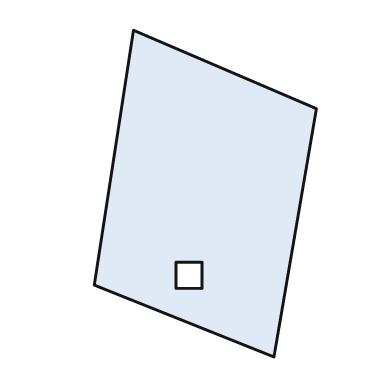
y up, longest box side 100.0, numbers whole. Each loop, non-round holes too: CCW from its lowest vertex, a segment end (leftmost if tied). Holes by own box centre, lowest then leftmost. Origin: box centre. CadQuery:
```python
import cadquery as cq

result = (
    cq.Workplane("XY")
    .moveTo(21.0, -50.0)
    .lineTo(34.0, 26.0)
    .lineTo(-22.0, 50.0)
    .lineTo(-34.0, -28.0)
    .close()
    .moveTo(-9.0, -29.0)
    .lineTo(-1.0, -29.0)
    .lineTo(-1.0, -21.0)
    .lineTo(-9.0, -21.0)
    .close()
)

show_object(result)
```